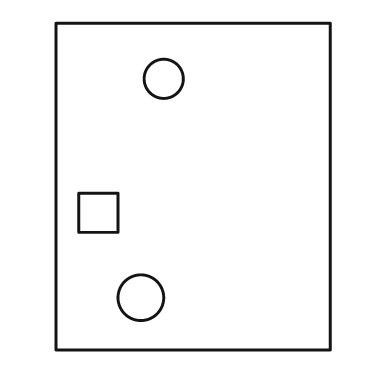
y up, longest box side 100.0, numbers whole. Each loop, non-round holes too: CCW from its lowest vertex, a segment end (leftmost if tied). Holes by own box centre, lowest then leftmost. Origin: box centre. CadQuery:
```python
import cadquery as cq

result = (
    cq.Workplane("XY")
    .moveTo(-42.0, -50.0)
    .lineTo(42.0, -50.0)
    .lineTo(42.0, 50.0)
    .lineTo(-42.0, 50.0)
    .close()
    .moveTo(-16.0, -34.0)
    .circle(7.0)
    .moveTo(-35.0, -14.0)
    .lineTo(-23.0, -14.0)
    .lineTo(-23.0, -2.0)
    .lineTo(-35.0, -2.0)
    .close()
    .moveTo(-9.0, 33.0)
    .circle(6.0)
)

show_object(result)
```